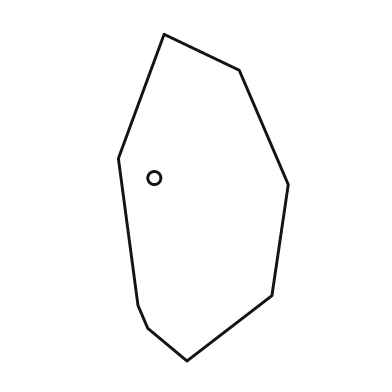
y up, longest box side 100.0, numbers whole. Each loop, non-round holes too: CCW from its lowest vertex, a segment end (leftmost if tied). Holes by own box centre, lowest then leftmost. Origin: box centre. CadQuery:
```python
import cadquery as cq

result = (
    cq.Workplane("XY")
    .moveTo(-5.0, -50.0)
    .lineTo(21.0, -30.0)
    .lineTo(26.0, 4.0)
    .lineTo(11.0, 39.0)
    .lineTo(-12.0, 50.0)
    .lineTo(-26.0, 12.0)
    .lineTo(-20.0, -33.0)
    .lineTo(-17.0, -40.0)
    .close()
    .moveTo(-15.0, 6.0)
    .circle(2.0)
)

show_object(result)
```